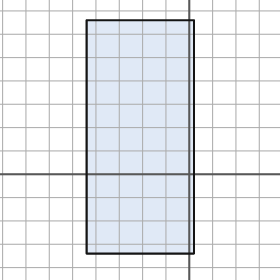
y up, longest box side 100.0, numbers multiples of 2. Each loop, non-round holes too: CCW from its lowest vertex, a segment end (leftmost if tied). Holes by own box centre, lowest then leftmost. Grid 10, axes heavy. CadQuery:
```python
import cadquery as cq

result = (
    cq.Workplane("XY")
    .moveTo(-44.0, -34.0)
    .lineTo(2.0, -34.0)
    .lineTo(2.0, 66.0)
    .lineTo(-44.0, 66.0)
    .close()
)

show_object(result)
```